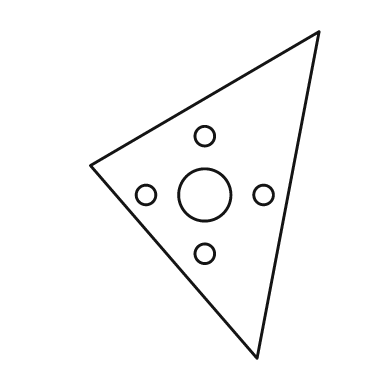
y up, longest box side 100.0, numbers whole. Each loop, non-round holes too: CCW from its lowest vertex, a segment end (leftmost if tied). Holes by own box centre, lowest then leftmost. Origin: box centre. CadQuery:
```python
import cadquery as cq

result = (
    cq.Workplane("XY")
    .moveTo(16.0, -50.0)
    .lineTo(35.0, 50.0)
    .lineTo(-35.0, 9.0)
    .close()
    .moveTo(0.0, -18.0)
    .circle(3.0)
    .moveTo(-18.0, 0.0)
    .circle(3.0)
    .moveTo(0.0, 0.0)
    .circle(8.0)
    .moveTo(18.0, 0.0)
    .circle(3.0)
    .moveTo(0.0, 18.0)
    .circle(3.0)
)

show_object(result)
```